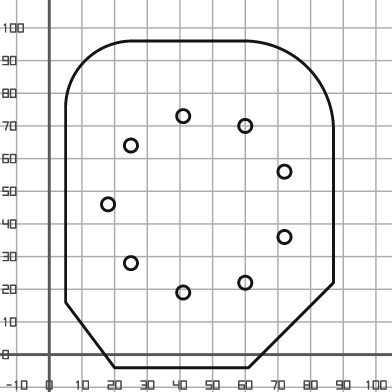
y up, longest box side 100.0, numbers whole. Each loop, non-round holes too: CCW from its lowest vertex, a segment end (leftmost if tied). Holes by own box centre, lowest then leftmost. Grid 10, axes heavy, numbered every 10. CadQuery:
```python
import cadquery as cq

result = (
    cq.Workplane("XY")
    .moveTo(20.0, -4.0)
    .lineTo(61.0, -4.0)
    .lineTo(87.0, 22.0)
    .lineTo(87.0, 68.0)
    .threePointArc((79.0, 88.0), (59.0, 96.0))
    .lineTo(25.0, 96.0)
    .threePointArc((11.0, 90.0), (5.0, 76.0))
    .lineTo(5.0, 16.0)
    .close()
    .moveTo(41.0, 19.0)
    .circle(2.0)
    .moveTo(60.0, 22.0)
    .circle(2.0)
    .moveTo(25.0, 28.0)
    .circle(2.0)
    .moveTo(72.0, 36.0)
    .circle(2.0)
    .moveTo(18.0, 46.0)
    .circle(2.0)
    .moveTo(72.0, 56.0)
    .circle(2.0)
    .moveTo(25.0, 64.0)
    .circle(2.0)
    .moveTo(60.0, 70.0)
    .circle(2.0)
    .moveTo(41.0, 73.0)
    .circle(2.0)
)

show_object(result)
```